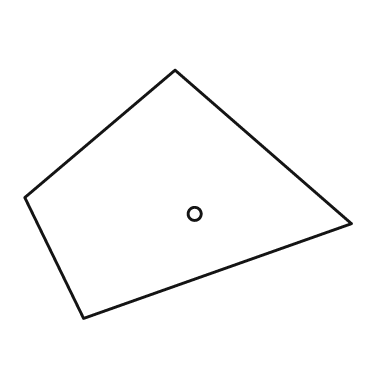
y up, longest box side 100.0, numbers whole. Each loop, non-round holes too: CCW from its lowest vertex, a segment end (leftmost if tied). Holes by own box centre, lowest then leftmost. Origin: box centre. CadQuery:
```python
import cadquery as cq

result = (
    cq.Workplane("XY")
    .moveTo(-32.0, -38.0)
    .lineTo(50.0, -9.0)
    .lineTo(-4.0, 38.0)
    .lineTo(-50.0, -1.0)
    .close()
    .moveTo(2.0, -6.0)
    .circle(2.0)
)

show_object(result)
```